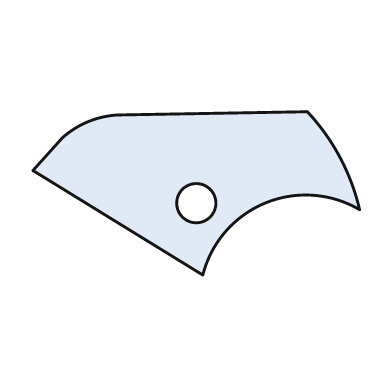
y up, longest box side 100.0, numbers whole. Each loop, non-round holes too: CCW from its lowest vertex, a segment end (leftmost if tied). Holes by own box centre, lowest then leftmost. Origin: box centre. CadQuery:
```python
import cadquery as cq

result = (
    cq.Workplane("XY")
    .moveTo(2.0, -25.0)
    .threePointArc((21.0, -3.0), (50.0, -5.0))
    .threePointArc((44.0, 11.0), (34.0, 25.0))
    .lineTo(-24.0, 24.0)
    .threePointArc((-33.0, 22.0), (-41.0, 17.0))
    .lineTo(-50.0, 7.0)
    .close()
    .moveTo(0.0, -3.0)
    .circle(6.0)
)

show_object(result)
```